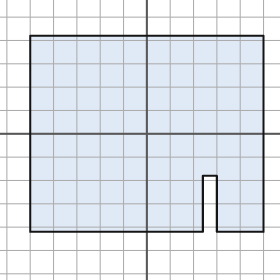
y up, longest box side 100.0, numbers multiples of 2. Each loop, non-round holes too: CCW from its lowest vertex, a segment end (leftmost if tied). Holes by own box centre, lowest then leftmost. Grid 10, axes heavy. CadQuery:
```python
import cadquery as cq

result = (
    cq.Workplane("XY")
    .moveTo(-50.0, -42.0)
    .lineTo(24.0, -42.0)
    .lineTo(24.0, -18.0)
    .lineTo(30.0, -18.0)
    .lineTo(30.0, -42.0)
    .lineTo(50.0, -42.0)
    .lineTo(50.0, 42.0)
    .lineTo(-50.0, 42.0)
    .close()
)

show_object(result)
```